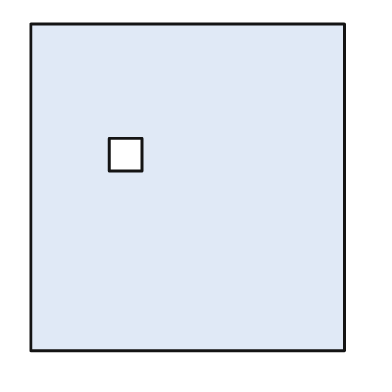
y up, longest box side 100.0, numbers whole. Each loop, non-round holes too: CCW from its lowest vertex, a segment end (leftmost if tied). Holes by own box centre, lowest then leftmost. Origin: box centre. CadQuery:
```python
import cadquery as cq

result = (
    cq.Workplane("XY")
    .moveTo(-48.0, -50.0)
    .lineTo(48.0, -50.0)
    .lineTo(48.0, 50.0)
    .lineTo(-48.0, 50.0)
    .close()
    .moveTo(-24.0, 5.0)
    .lineTo(-14.0, 5.0)
    .lineTo(-14.0, 15.0)
    .lineTo(-24.0, 15.0)
    .close()
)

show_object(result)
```